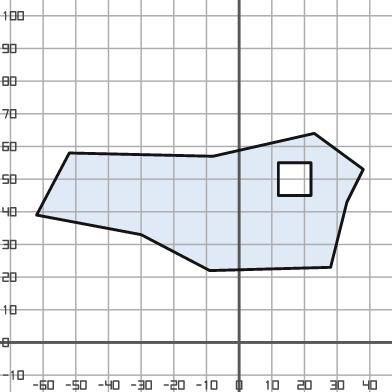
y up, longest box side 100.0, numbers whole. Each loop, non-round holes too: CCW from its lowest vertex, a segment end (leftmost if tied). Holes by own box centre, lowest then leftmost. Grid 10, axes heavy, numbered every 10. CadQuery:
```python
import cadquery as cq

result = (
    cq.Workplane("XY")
    .moveTo(-9.0, 22.0)
    .lineTo(28.0, 23.0)
    .lineTo(33.0, 43.0)
    .lineTo(38.0, 53.0)
    .lineTo(23.0, 64.0)
    .lineTo(-8.0, 57.0)
    .lineTo(-52.0, 58.0)
    .lineTo(-62.0, 39.0)
    .lineTo(-30.0, 33.0)
    .close()
    .moveTo(12.0, 45.0)
    .lineTo(22.0, 45.0)
    .lineTo(22.0, 55.0)
    .lineTo(12.0, 55.0)
    .close()
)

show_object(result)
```